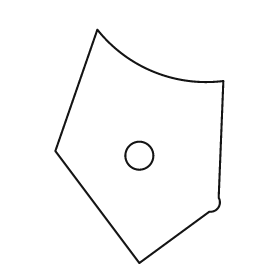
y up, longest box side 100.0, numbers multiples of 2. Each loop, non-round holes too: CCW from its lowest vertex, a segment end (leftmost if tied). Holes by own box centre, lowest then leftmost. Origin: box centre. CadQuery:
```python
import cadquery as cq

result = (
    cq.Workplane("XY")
    .moveTo(0.0, -50.0)
    .lineTo(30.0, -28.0)
    .threePointArc((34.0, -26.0), (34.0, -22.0))
    .lineTo(36.0, 28.0)
    .threePointArc((6.0, 32.0), (-18.0, 50.0))
    .lineTo(-36.0, -2.0)
    .close()
    .moveTo(0.0, -4.0)
    .circle(6.0)
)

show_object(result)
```